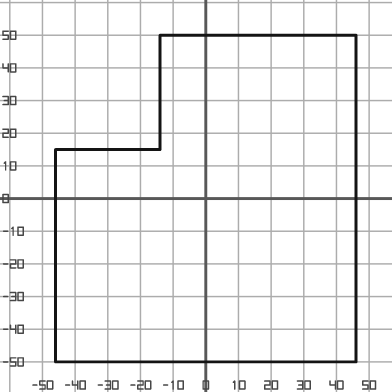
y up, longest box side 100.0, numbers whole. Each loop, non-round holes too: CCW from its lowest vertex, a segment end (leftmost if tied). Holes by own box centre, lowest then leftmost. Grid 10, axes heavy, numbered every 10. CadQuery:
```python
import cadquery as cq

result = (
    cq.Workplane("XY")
    .moveTo(-46.0, -50.0)
    .lineTo(46.0, -50.0)
    .lineTo(46.0, 50.0)
    .lineTo(-14.0, 50.0)
    .lineTo(-14.0, 15.0)
    .lineTo(-46.0, 15.0)
    .close()
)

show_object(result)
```